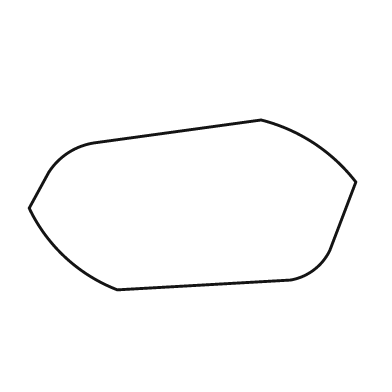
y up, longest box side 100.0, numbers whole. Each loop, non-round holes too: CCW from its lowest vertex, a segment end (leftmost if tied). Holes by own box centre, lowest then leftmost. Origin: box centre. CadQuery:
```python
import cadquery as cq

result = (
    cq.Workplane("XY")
    .moveTo(-23.0, -26.0)
    .lineTo(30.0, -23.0)
    .threePointArc((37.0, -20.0), (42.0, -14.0))
    .lineTo(50.0, 7.0)
    .threePointArc((37.0, 19.0), (21.0, 26.0))
    .lineTo(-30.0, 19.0)
    .threePointArc((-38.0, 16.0), (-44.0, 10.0))
    .lineTo(-50.0, -1.0)
    .threePointArc((-39.0, -16.0), (-23.0, -26.0))
    .close()
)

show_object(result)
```